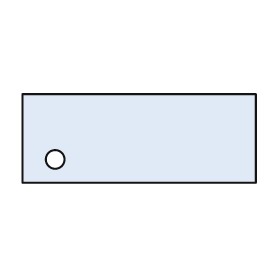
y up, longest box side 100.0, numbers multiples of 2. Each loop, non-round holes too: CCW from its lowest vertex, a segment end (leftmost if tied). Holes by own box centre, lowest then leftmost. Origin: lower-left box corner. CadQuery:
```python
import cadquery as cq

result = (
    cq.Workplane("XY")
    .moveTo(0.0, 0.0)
    .lineTo(100.0, 0.0)
    .lineTo(100.0, 38.0)
    .lineTo(0.0, 38.0)
    .close()
    .moveTo(14.0, 10.0)
    .circle(4.0)
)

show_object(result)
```